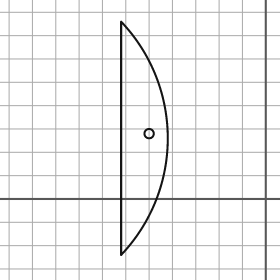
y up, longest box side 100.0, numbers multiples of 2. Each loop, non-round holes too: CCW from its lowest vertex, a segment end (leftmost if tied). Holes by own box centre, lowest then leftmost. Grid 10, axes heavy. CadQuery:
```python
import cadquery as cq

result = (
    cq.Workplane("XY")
    .moveTo(-62.0, -24.0)
    .threePointArc((-42.0, 26.0), (-62.0, 76.0))
    .close()
    .moveTo(-50.0, 28.0)
    .circle(2.0)
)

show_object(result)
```